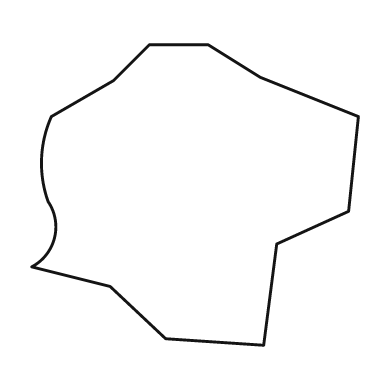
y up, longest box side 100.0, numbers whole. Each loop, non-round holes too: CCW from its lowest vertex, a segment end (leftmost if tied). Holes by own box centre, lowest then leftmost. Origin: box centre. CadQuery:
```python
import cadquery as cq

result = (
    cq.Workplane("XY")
    .moveTo(21.0, -46.0)
    .lineTo(25.0, -15.0)
    .lineTo(47.0, -5.0)
    .lineTo(50.0, 24.0)
    .lineTo(20.0, 36.0)
    .lineTo(4.0, 46.0)
    .lineTo(-14.0, 46.0)
    .lineTo(-25.0, 35.0)
    .lineTo(-44.0, 24.0)
    .threePointArc((-47.0, 11.0), (-45.0, -2.0))
    .threePointArc((-43.0, -13.0), (-50.0, -22.0))
    .lineTo(-26.0, -28.0)
    .lineTo(-9.0, -44.0)
    .close()
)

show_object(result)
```